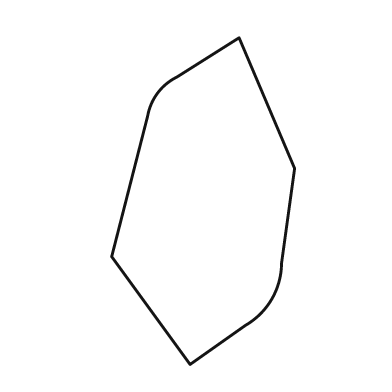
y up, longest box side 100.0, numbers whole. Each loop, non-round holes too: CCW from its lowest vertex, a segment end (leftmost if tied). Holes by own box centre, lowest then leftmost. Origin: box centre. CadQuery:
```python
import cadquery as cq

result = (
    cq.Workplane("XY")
    .moveTo(-4.0, -50.0)
    .lineTo(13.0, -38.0)
    .threePointArc((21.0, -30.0), (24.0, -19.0))
    .lineTo(28.0, 10.0)
    .lineTo(11.0, 50.0)
    .lineTo(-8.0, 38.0)
    .threePointArc((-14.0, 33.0), (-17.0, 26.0))
    .lineTo(-28.0, -17.0)
    .close()
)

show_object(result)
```